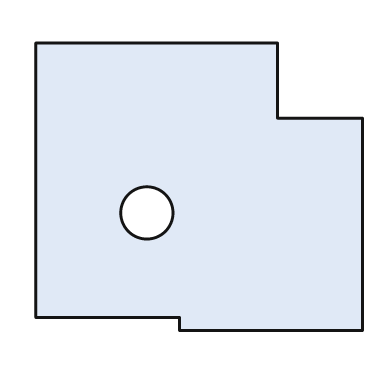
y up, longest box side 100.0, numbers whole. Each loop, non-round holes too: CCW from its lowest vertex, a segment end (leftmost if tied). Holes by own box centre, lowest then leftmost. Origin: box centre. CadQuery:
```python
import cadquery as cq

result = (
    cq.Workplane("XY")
    .moveTo(-6.0, -44.0)
    .lineTo(50.0, -44.0)
    .lineTo(50.0, 21.0)
    .lineTo(24.0, 21.0)
    .lineTo(24.0, 44.0)
    .lineTo(-50.0, 44.0)
    .lineTo(-50.0, -40.0)
    .lineTo(-6.0, -40.0)
    .close()
    .moveTo(-16.0, -8.0)
    .circle(8.0)
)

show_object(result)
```